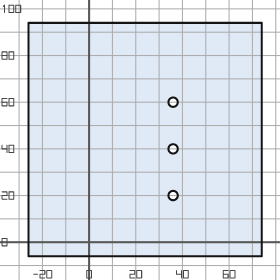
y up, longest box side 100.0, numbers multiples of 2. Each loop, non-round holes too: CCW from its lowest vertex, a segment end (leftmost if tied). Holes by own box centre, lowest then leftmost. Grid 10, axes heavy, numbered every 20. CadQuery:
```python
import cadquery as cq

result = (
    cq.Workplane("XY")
    .moveTo(-26.0, -6.0)
    .lineTo(74.0, -6.0)
    .lineTo(74.0, 94.0)
    .lineTo(-26.0, 94.0)
    .close()
    .moveTo(36.0, 20.0)
    .circle(2.0)
    .moveTo(36.0, 40.0)
    .circle(2.0)
    .moveTo(36.0, 60.0)
    .circle(2.0)
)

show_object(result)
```